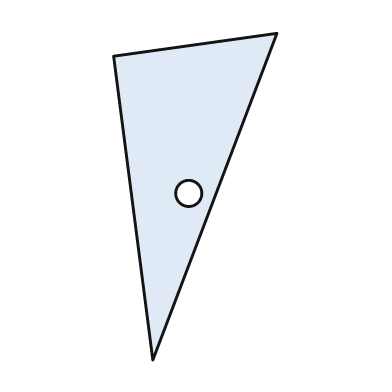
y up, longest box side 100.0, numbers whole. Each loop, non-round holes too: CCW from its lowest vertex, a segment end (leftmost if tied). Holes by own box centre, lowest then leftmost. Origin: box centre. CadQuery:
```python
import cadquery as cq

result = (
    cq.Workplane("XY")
    .moveTo(-13.0, -50.0)
    .lineTo(25.0, 50.0)
    .lineTo(-25.0, 43.0)
    .close()
    .moveTo(-2.0, 1.0)
    .circle(4.0)
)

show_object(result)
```